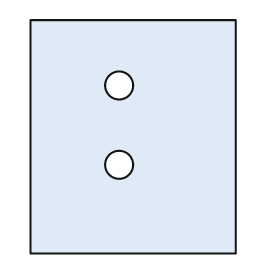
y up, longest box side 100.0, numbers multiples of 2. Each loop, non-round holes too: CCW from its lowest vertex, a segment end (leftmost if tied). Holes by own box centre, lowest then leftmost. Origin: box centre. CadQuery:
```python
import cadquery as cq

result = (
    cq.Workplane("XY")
    .moveTo(-44.0, -50.0)
    .lineTo(44.0, -50.0)
    .lineTo(44.0, 50.0)
    .lineTo(-44.0, 50.0)
    .close()
    .moveTo(-6.0, -12.0)
    .circle(6.0)
    .moveTo(-6.0, 22.0)
    .circle(6.0)
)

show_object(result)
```